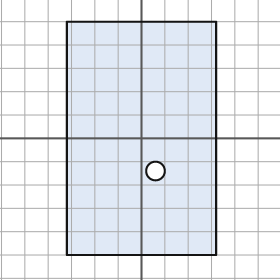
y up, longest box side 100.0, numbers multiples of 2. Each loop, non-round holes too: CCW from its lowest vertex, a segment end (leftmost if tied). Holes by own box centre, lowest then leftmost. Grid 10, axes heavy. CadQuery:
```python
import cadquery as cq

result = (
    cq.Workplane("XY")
    .moveTo(-32.0, -50.0)
    .lineTo(32.0, -50.0)
    .lineTo(32.0, 50.0)
    .lineTo(-32.0, 50.0)
    .close()
    .moveTo(6.0, -14.0)
    .circle(4.0)
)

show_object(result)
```